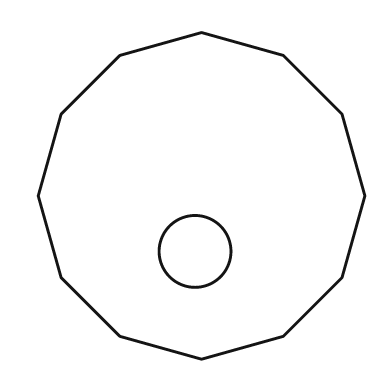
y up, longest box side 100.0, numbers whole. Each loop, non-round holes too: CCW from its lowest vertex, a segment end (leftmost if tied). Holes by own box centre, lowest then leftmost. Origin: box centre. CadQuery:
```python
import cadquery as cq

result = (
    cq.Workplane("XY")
    .moveTo(0.0, -50.0)
    .lineTo(25.0, -43.0)
    .lineTo(43.0, -25.0)
    .lineTo(50.0, 0.0)
    .lineTo(43.0, 25.0)
    .lineTo(25.0, 43.0)
    .lineTo(0.0, 50.0)
    .lineTo(-25.0, 43.0)
    .lineTo(-43.0, 25.0)
    .lineTo(-50.0, 0.0)
    .lineTo(-43.0, -25.0)
    .lineTo(-25.0, -43.0)
    .close()
    .moveTo(-2.0, -17.0)
    .circle(11.0)
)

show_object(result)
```